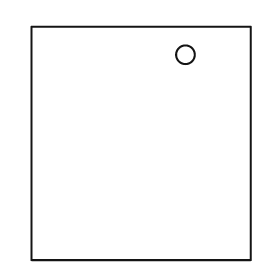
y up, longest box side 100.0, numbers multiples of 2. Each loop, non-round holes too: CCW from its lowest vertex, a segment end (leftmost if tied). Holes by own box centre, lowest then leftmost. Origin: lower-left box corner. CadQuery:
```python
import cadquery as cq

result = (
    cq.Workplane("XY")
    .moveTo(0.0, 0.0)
    .lineTo(94.0, 0.0)
    .lineTo(94.0, 100.0)
    .lineTo(0.0, 100.0)
    .close()
    .moveTo(66.0, 88.0)
    .circle(4.0)
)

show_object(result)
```